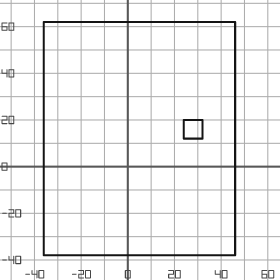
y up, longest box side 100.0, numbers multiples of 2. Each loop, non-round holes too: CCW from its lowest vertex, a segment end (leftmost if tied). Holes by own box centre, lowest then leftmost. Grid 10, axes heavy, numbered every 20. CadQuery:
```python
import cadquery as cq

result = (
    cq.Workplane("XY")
    .moveTo(-36.0, -38.0)
    .lineTo(46.0, -38.0)
    .lineTo(46.0, 62.0)
    .lineTo(-36.0, 62.0)
    .close()
    .moveTo(24.0, 12.0)
    .lineTo(32.0, 12.0)
    .lineTo(32.0, 20.0)
    .lineTo(24.0, 20.0)
    .close()
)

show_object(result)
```